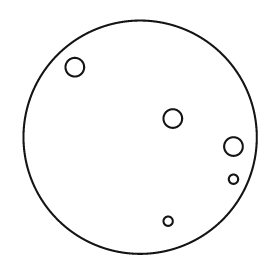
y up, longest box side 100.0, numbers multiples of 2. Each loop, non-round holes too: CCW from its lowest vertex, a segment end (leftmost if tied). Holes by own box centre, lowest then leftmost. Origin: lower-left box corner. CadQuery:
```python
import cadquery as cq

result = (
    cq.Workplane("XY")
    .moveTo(50.0, 50.0)
    .circle(50.0)
    .moveTo(62.0, 14.0)
    .circle(2.0)
    .moveTo(90.0, 32.0)
    .circle(2.0)
    .moveTo(90.0, 46.0)
    .circle(4.0)
    .moveTo(64.0, 58.0)
    .circle(4.0)
    .moveTo(22.0, 80.0)
    .circle(4.0)
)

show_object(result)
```